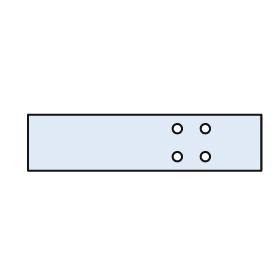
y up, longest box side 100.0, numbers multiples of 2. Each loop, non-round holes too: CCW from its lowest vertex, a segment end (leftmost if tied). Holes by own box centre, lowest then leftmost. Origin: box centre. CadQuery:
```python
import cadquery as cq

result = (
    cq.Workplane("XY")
    .moveTo(-50.0, -12.0)
    .lineTo(50.0, -12.0)
    .lineTo(50.0, 12.0)
    .lineTo(-50.0, 12.0)
    .close()
    .moveTo(14.0, -6.0)
    .circle(2.0)
    .moveTo(26.0, -6.0)
    .circle(2.0)
    .moveTo(14.0, 6.0)
    .circle(2.0)
    .moveTo(26.0, 6.0)
    .circle(2.0)
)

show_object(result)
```